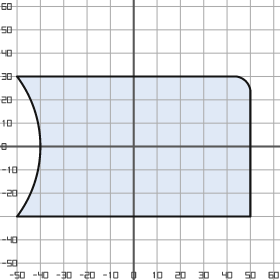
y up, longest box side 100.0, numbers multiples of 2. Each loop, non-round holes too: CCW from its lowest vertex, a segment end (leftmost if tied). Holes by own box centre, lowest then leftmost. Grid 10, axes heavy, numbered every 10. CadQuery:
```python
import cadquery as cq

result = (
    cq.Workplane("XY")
    .moveTo(-50.0, -30.0)
    .lineTo(50.0, -30.0)
    .lineTo(50.0, 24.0)
    .threePointArc((48.0, 28.0), (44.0, 30.0))
    .lineTo(-50.0, 30.0)
    .threePointArc((-40.0, 0.0), (-50.0, -30.0))
    .close()
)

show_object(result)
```